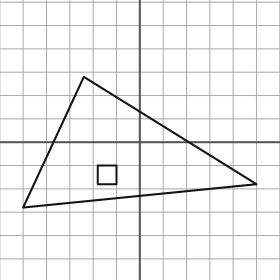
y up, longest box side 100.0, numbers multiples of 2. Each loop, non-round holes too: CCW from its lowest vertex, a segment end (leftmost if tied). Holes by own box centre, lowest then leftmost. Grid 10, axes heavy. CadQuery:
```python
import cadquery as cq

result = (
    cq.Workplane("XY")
    .moveTo(-50.0, -28.0)
    .lineTo(50.0, -18.0)
    .lineTo(-24.0, 28.0)
    .close()
    .moveTo(-18.0, -18.0)
    .lineTo(-10.0, -18.0)
    .lineTo(-10.0, -10.0)
    .lineTo(-18.0, -10.0)
    .close()
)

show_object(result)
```